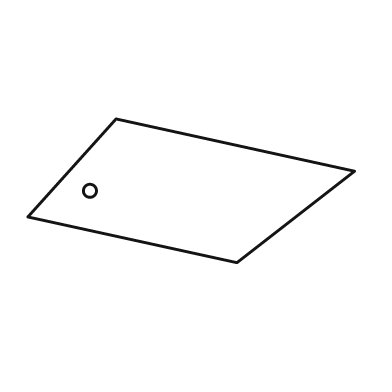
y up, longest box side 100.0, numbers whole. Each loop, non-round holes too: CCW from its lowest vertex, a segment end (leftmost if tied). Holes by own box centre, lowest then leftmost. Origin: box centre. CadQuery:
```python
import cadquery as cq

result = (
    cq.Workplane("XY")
    .moveTo(14.0, -22.0)
    .lineTo(50.0, 6.0)
    .lineTo(-23.0, 22.0)
    .lineTo(-50.0, -8.0)
    .close()
    .moveTo(-31.0, 0.0)
    .circle(2.0)
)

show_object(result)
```